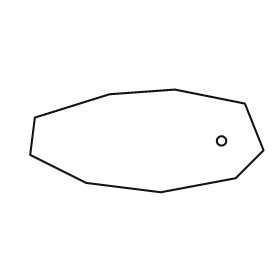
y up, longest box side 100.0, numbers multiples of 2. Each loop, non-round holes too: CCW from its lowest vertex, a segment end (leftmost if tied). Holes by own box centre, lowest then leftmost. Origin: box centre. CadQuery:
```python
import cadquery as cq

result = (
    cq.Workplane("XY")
    .moveTo(6.0, -22.0)
    .lineTo(38.0, -16.0)
    .lineTo(50.0, -4.0)
    .lineTo(42.0, 16.0)
    .lineTo(12.0, 22.0)
    .lineTo(-16.0, 20.0)
    .lineTo(-48.0, 10.0)
    .lineTo(-50.0, -6.0)
    .lineTo(-26.0, -18.0)
    .close()
    .moveTo(32.0, 0.0)
    .circle(2.0)
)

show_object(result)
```